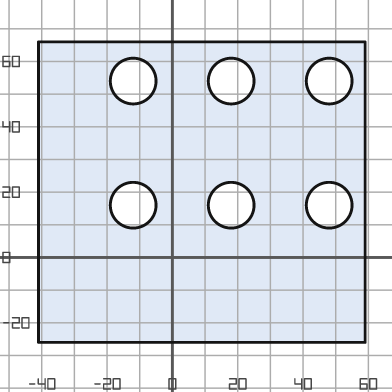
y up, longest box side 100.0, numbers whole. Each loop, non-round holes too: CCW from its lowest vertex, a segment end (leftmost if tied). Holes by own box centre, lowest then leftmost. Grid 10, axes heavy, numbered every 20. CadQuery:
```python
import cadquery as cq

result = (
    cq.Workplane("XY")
    .moveTo(-41.0, -26.0)
    .lineTo(59.0, -26.0)
    .lineTo(59.0, 66.0)
    .lineTo(-41.0, 66.0)
    .close()
    .moveTo(-12.0, 16.0)
    .circle(7.0)
    .moveTo(18.0, 16.0)
    .circle(7.0)
    .moveTo(48.0, 16.0)
    .circle(7.0)
    .moveTo(-12.0, 54.0)
    .circle(7.0)
    .moveTo(18.0, 54.0)
    .circle(7.0)
    .moveTo(48.0, 54.0)
    .circle(7.0)
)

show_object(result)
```